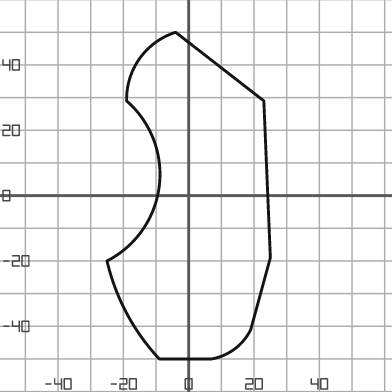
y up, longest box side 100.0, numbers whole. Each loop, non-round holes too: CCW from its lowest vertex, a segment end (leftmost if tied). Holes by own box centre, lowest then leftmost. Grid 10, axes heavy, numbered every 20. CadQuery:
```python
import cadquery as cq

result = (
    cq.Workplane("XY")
    .moveTo(-9.0, -50.0)
    .lineTo(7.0, -50.0)
    .threePointArc((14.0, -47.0), (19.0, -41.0))
    .lineTo(25.0, -19.0)
    .lineTo(23.0, 29.0)
    .lineTo(-4.0, 50.0)
    .threePointArc((-15.0, 42.0), (-19.0, 29.0))
    .threePointArc((-9.0, 3.0), (-25.0, -20.0))
    .threePointArc((-19.0, -36.0), (-9.0, -50.0))
    .close()
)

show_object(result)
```